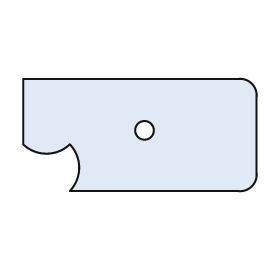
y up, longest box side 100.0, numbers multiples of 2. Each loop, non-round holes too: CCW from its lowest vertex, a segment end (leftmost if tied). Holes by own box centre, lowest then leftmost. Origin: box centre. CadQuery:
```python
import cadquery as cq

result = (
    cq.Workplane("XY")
    .moveTo(-30.0, -24.0)
    .lineTo(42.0, -24.0)
    .threePointArc((48.0, -22.0), (50.0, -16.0))
    .lineTo(50.0, 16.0)
    .threePointArc((48.0, 22.0), (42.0, 24.0))
    .lineTo(-50.0, 24.0)
    .lineTo(-50.0, -4.0)
    .threePointArc((-40.0, -8.0), (-30.0, -4.0))
    .threePointArc((-26.0, -14.0), (-30.0, -24.0))
    .close()
    .moveTo(2.0, 2.0)
    .circle(4.0)
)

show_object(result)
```